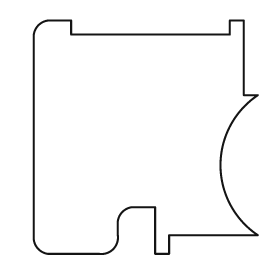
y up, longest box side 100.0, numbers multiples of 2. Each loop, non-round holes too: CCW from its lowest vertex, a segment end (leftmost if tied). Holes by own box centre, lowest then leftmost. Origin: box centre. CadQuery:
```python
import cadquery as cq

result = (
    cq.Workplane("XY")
    .moveTo(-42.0, -50.0)
    .lineTo(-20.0, -50.0)
    .threePointArc((-14.0, -48.0), (-12.0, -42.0))
    .lineTo(-12.0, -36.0)
    .threePointArc((-10.0, -32.0), (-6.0, -30.0))
    .lineTo(4.0, -30.0)
    .lineTo(4.0, -50.0)
    .lineTo(10.0, -50.0)
    .lineTo(10.0, -42.0)
    .lineTo(48.0, -42.0)
    .threePointArc((32.0, -12.0), (48.0, 18.0))
    .lineTo(42.0, 18.0)
    .lineTo(42.0, 50.0)
    .lineTo(36.0, 50.0)
    .lineTo(36.0, 44.0)
    .lineTo(-32.0, 44.0)
    .lineTo(-32.0, 50.0)
    .lineTo(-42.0, 50.0)
    .threePointArc((-46.0, 48.0), (-48.0, 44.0))
    .lineTo(-48.0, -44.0)
    .threePointArc((-46.0, -48.0), (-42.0, -50.0))
    .close()
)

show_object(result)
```